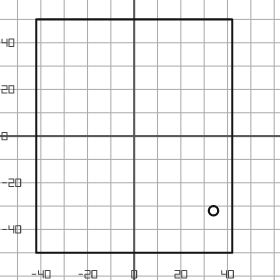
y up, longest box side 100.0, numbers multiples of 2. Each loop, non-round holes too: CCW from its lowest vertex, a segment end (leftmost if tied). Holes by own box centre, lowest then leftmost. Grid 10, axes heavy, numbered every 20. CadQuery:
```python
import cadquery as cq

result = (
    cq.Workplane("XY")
    .moveTo(-42.0, -50.0)
    .lineTo(42.0, -50.0)
    .lineTo(42.0, 50.0)
    .lineTo(-42.0, 50.0)
    .close()
    .moveTo(34.0, -32.0)
    .circle(2.0)
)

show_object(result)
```